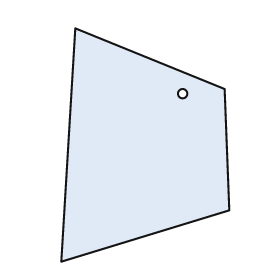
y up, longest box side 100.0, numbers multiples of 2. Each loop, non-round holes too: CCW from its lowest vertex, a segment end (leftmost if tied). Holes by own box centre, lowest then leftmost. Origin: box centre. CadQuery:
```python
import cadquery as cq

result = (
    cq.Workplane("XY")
    .moveTo(-36.0, -50.0)
    .lineTo(36.0, -28.0)
    .lineTo(34.0, 24.0)
    .lineTo(-30.0, 50.0)
    .close()
    .moveTo(16.0, 22.0)
    .circle(2.0)
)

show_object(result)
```